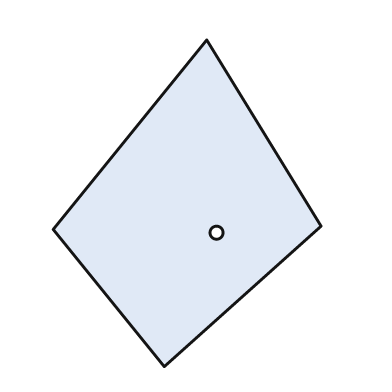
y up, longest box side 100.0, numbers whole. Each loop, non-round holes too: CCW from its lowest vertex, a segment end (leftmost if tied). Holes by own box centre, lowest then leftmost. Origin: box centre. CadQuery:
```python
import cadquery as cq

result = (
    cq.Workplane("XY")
    .moveTo(-7.0, -50.0)
    .lineTo(41.0, -7.0)
    .lineTo(6.0, 50.0)
    .lineTo(-41.0, -8.0)
    .close()
    .moveTo(9.0, -9.0)
    .circle(2.0)
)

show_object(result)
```